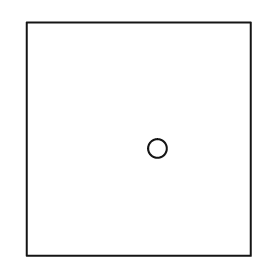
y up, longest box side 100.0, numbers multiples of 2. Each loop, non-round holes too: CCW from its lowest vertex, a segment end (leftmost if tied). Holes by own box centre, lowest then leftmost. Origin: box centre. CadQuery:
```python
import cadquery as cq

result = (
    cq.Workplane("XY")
    .moveTo(-48.0, -50.0)
    .lineTo(48.0, -50.0)
    .lineTo(48.0, 50.0)
    .lineTo(-48.0, 50.0)
    .close()
    .moveTo(8.0, -4.0)
    .circle(4.0)
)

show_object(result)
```